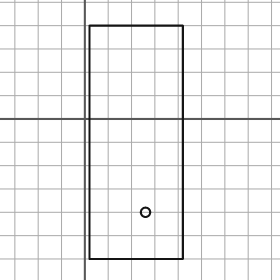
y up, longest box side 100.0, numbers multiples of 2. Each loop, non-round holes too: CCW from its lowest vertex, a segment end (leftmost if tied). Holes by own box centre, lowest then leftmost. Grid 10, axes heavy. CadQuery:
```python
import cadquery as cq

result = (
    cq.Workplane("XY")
    .moveTo(2.0, -60.0)
    .lineTo(42.0, -60.0)
    .lineTo(42.0, 40.0)
    .lineTo(2.0, 40.0)
    .close()
    .moveTo(26.0, -40.0)
    .circle(2.0)
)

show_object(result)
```